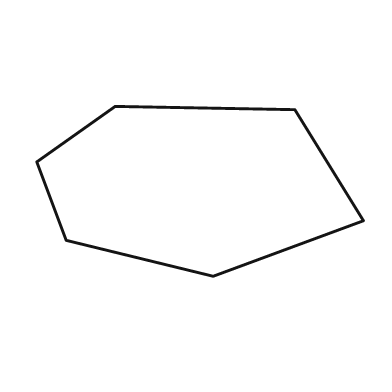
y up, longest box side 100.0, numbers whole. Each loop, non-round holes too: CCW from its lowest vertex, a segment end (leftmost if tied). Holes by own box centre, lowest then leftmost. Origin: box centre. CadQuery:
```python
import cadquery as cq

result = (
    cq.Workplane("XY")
    .moveTo(4.0, -26.0)
    .lineTo(50.0, -9.0)
    .lineTo(29.0, 25.0)
    .lineTo(-26.0, 26.0)
    .lineTo(-50.0, 9.0)
    .lineTo(-41.0, -15.0)
    .close()
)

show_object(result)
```